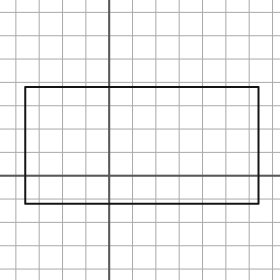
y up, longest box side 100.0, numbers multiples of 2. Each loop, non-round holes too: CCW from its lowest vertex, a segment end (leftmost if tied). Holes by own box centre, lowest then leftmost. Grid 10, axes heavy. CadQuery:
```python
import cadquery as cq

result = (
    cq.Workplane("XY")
    .moveTo(-36.0, -12.0)
    .lineTo(64.0, -12.0)
    .lineTo(64.0, 38.0)
    .lineTo(-36.0, 38.0)
    .close()
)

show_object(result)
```